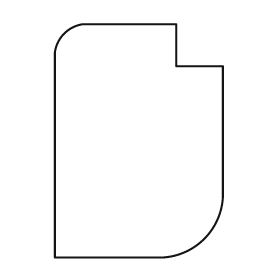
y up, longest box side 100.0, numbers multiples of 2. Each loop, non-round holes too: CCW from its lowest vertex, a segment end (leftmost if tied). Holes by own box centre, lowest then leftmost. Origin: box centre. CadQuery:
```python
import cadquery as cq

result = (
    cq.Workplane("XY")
    .moveTo(-36.0, -50.0)
    .lineTo(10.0, -50.0)
    .threePointArc((28.0, -42.0), (36.0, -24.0))
    .lineTo(36.0, 32.0)
    .lineTo(16.0, 32.0)
    .lineTo(16.0, 50.0)
    .lineTo(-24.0, 50.0)
    .threePointArc((-32.0, 46.0), (-36.0, 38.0))
    .close()
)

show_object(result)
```